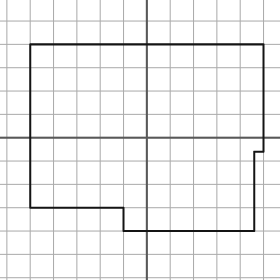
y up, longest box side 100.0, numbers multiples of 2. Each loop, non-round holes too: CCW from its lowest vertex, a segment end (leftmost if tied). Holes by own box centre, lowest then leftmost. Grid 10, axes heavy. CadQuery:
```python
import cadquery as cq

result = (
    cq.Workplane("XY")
    .moveTo(-10.0, -40.0)
    .lineTo(46.0, -40.0)
    .lineTo(46.0, -6.0)
    .lineTo(50.0, -6.0)
    .lineTo(50.0, 40.0)
    .lineTo(-50.0, 40.0)
    .lineTo(-50.0, -30.0)
    .lineTo(-10.0, -30.0)
    .close()
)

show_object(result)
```